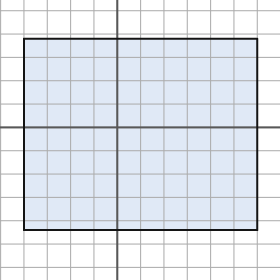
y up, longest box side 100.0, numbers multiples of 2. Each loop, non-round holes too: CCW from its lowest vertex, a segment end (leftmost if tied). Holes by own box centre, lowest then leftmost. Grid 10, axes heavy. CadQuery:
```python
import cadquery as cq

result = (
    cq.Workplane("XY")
    .moveTo(-40.0, -44.0)
    .lineTo(60.0, -44.0)
    .lineTo(60.0, 38.0)
    .lineTo(-40.0, 38.0)
    .close()
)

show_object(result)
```